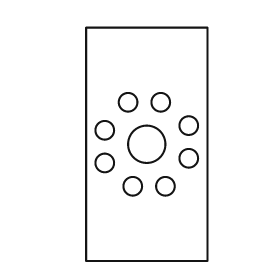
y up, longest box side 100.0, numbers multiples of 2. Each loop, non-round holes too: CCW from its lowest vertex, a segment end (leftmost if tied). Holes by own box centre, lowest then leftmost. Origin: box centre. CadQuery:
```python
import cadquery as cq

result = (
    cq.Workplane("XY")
    .moveTo(-26.0, -50.0)
    .lineTo(26.0, -50.0)
    .lineTo(26.0, 50.0)
    .lineTo(-26.0, 50.0)
    .close()
    .moveTo(-6.0, -18.0)
    .circle(4.0)
    .moveTo(8.0, -18.0)
    .circle(4.0)
    .moveTo(-18.0, -8.0)
    .circle(4.0)
    .moveTo(18.0, -6.0)
    .circle(4.0)
    .moveTo(0.0, 0.0)
    .circle(8.0)
    .moveTo(-18.0, 6.0)
    .circle(4.0)
    .moveTo(18.0, 8.0)
    .circle(4.0)
    .moveTo(-8.0, 18.0)
    .circle(4.0)
    .moveTo(6.0, 18.0)
    .circle(4.0)
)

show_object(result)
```